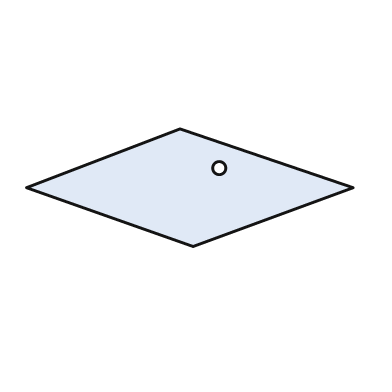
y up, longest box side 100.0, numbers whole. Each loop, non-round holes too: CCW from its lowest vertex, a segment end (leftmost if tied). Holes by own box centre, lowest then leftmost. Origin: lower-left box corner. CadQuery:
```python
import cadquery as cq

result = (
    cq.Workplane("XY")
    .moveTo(51.0, 0.0)
    .lineTo(100.0, 18.0)
    .lineTo(47.0, 36.0)
    .lineTo(0.0, 18.0)
    .close()
    .moveTo(59.0, 24.0)
    .circle(2.0)
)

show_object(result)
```